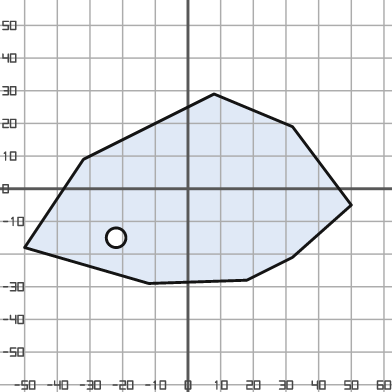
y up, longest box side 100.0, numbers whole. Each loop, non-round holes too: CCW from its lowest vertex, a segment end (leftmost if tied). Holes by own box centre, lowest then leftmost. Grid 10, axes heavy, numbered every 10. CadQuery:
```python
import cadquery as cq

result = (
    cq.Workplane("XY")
    .moveTo(-12.0, -29.0)
    .lineTo(18.0, -28.0)
    .lineTo(32.0, -21.0)
    .lineTo(50.0, -5.0)
    .lineTo(32.0, 19.0)
    .lineTo(8.0, 29.0)
    .lineTo(-32.0, 9.0)
    .lineTo(-50.0, -18.0)
    .close()
    .moveTo(-22.0, -15.0)
    .circle(3.0)
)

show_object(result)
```